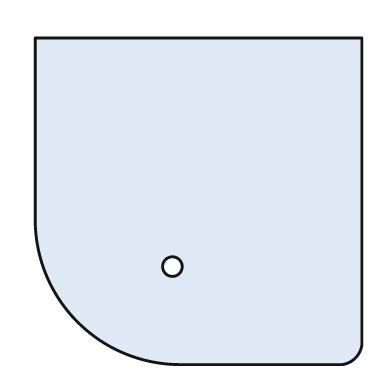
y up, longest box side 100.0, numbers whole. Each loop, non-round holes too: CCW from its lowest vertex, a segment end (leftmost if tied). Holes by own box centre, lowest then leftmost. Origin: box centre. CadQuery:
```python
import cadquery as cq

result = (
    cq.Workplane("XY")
    .moveTo(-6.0, -50.0)
    .lineTo(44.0, -50.0)
    .threePointArc((48.0, -48.0), (50.0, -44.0))
    .lineTo(50.0, 50.0)
    .lineTo(-50.0, 50.0)
    .lineTo(-50.0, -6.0)
    .threePointArc((-37.0, -37.0), (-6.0, -50.0))
    .close()
    .moveTo(-8.0, -20.0)
    .circle(3.0)
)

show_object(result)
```